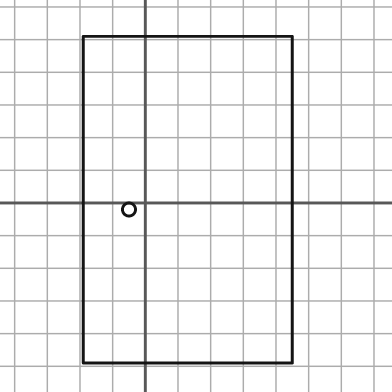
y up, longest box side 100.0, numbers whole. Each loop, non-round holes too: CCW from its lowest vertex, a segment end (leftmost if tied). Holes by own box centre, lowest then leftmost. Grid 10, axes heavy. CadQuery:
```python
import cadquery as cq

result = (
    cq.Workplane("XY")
    .moveTo(-19.0, -49.0)
    .lineTo(45.0, -49.0)
    .lineTo(45.0, 51.0)
    .lineTo(-19.0, 51.0)
    .close()
    .moveTo(-5.0, -2.0)
    .circle(2.0)
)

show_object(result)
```